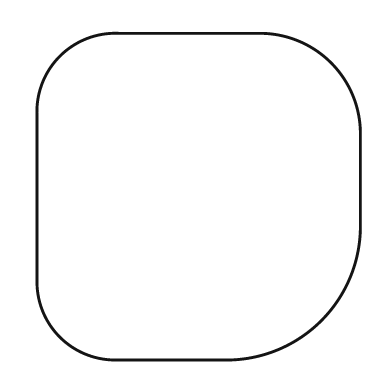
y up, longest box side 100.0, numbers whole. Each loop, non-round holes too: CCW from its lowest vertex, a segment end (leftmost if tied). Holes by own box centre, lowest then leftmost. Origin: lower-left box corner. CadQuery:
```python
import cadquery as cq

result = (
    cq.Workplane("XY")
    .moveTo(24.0, 0.0)
    .lineTo(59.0, 0.0)
    .threePointArc((87.0, 12.0), (99.0, 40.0))
    .lineTo(99.0, 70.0)
    .threePointArc((90.0, 91.0), (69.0, 100.0))
    .lineTo(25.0, 100.0)
    .threePointArc((7.0, 93.0), (0.0, 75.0))
    .lineTo(0.0, 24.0)
    .threePointArc((7.0, 7.0), (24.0, 0.0))
    .close()
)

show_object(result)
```